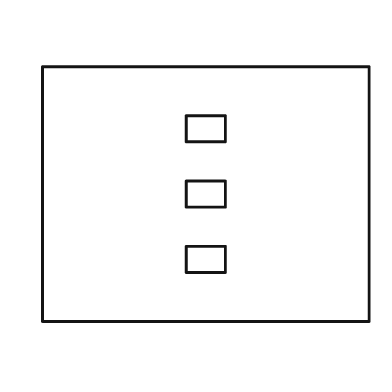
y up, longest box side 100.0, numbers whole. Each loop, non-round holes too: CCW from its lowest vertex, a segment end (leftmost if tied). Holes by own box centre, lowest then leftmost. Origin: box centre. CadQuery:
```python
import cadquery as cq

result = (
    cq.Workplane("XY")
    .moveTo(-50.0, -39.0)
    .lineTo(50.0, -39.0)
    .lineTo(50.0, 39.0)
    .lineTo(-50.0, 39.0)
    .close()
    .moveTo(-6.0, -24.0)
    .lineTo(6.0, -24.0)
    .lineTo(6.0, -16.0)
    .lineTo(-6.0, -16.0)
    .close()
    .moveTo(-6.0, -4.0)
    .lineTo(6.0, -4.0)
    .lineTo(6.0, 4.0)
    .lineTo(-6.0, 4.0)
    .close()
    .moveTo(-6.0, 16.0)
    .lineTo(6.0, 16.0)
    .lineTo(6.0, 24.0)
    .lineTo(-6.0, 24.0)
    .close()
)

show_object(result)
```